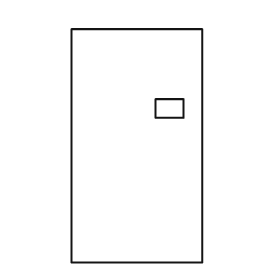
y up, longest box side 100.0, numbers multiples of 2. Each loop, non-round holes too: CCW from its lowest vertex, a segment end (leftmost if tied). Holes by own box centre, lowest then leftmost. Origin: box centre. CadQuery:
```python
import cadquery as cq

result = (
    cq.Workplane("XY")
    .moveTo(-28.0, -50.0)
    .lineTo(28.0, -50.0)
    .lineTo(28.0, 50.0)
    .lineTo(-28.0, 50.0)
    .close()
    .moveTo(8.0, 12.0)
    .lineTo(20.0, 12.0)
    .lineTo(20.0, 20.0)
    .lineTo(8.0, 20.0)
    .close()
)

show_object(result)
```